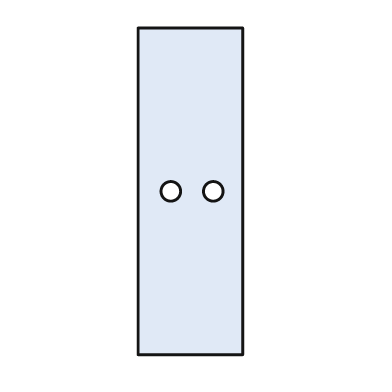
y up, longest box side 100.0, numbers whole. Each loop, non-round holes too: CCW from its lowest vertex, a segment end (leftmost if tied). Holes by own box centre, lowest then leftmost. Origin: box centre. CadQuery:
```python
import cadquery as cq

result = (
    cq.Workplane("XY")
    .moveTo(-16.0, -50.0)
    .lineTo(16.0, -50.0)
    .lineTo(16.0, 50.0)
    .lineTo(-16.0, 50.0)
    .close()
    .moveTo(-6.0, 0.0)
    .circle(3.0)
    .moveTo(7.0, 0.0)
    .circle(3.0)
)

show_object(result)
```